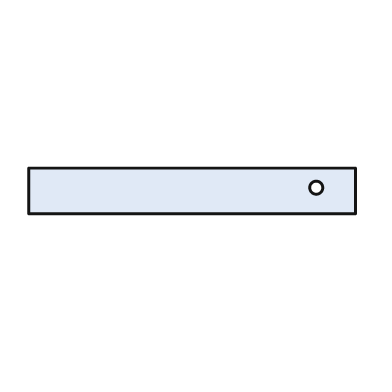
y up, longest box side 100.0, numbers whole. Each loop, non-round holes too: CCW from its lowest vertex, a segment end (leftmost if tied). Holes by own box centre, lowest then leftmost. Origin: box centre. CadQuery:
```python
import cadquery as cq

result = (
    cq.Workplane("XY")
    .moveTo(-50.0, -7.0)
    .lineTo(50.0, -7.0)
    .lineTo(50.0, 7.0)
    .lineTo(-50.0, 7.0)
    .close()
    .moveTo(38.0, 1.0)
    .circle(2.0)
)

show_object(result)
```